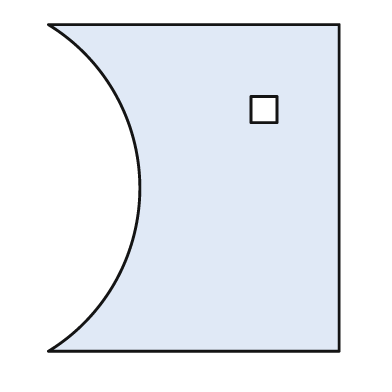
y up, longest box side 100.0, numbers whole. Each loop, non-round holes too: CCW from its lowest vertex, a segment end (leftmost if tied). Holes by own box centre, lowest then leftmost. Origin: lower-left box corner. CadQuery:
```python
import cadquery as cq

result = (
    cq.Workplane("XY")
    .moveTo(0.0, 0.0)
    .lineTo(89.0, 0.0)
    .lineTo(89.0, 100.0)
    .lineTo(0.0, 100.0)
    .threePointArc((28.0, 50.0), (0.0, 0.0))
    .close()
    .moveTo(62.0, 70.0)
    .lineTo(70.0, 70.0)
    .lineTo(70.0, 78.0)
    .lineTo(62.0, 78.0)
    .close()
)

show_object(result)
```